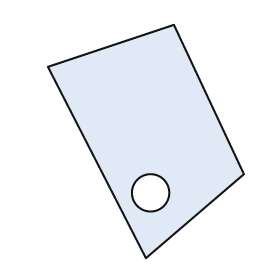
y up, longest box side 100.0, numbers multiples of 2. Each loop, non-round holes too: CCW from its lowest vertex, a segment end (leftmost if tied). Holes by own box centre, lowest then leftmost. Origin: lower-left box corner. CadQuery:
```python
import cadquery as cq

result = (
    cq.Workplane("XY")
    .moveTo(42.0, 0.0)
    .lineTo(84.0, 36.0)
    .lineTo(54.0, 100.0)
    .lineTo(0.0, 82.0)
    .close()
    .moveTo(44.0, 28.0)
    .circle(8.0)
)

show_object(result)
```